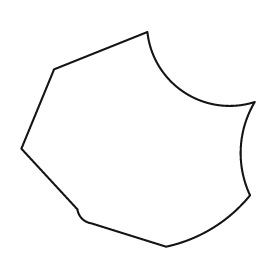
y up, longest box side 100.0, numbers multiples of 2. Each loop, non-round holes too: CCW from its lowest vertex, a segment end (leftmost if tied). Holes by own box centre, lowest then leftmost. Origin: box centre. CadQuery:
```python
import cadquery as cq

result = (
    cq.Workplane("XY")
    .moveTo(12.0, -46.0)
    .threePointArc((32.0, -38.0), (48.0, -24.0))
    .threePointArc((44.0, -4.0), (50.0, 16.0))
    .threePointArc((20.0, 20.0), (4.0, 46.0))
    .lineTo(-36.0, 30.0)
    .lineTo(-50.0, -4.0)
    .lineTo(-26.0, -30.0)
    .threePointArc((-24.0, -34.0), (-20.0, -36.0))
    .close()
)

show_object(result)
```